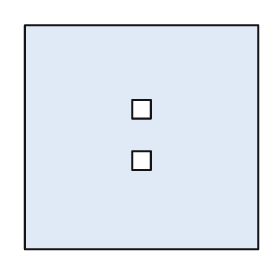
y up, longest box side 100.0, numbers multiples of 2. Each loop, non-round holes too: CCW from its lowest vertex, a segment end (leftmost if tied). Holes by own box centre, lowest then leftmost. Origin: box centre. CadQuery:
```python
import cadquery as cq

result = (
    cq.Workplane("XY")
    .moveTo(-50.0, -48.0)
    .lineTo(50.0, -48.0)
    .lineTo(50.0, 48.0)
    .lineTo(-50.0, 48.0)
    .close()
    .moveTo(-4.0, -14.0)
    .lineTo(4.0, -14.0)
    .lineTo(4.0, -6.0)
    .lineTo(-4.0, -6.0)
    .close()
    .moveTo(-4.0, 8.0)
    .lineTo(4.0, 8.0)
    .lineTo(4.0, 16.0)
    .lineTo(-4.0, 16.0)
    .close()
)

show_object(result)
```